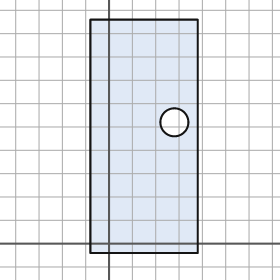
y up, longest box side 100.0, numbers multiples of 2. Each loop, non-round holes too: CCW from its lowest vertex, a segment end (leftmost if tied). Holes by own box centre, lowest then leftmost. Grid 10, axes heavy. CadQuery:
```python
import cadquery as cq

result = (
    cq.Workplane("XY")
    .moveTo(-8.0, -4.0)
    .lineTo(38.0, -4.0)
    .lineTo(38.0, 96.0)
    .lineTo(-8.0, 96.0)
    .close()
    .moveTo(28.0, 52.0)
    .circle(6.0)
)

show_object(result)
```